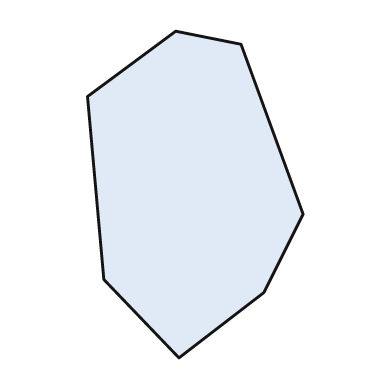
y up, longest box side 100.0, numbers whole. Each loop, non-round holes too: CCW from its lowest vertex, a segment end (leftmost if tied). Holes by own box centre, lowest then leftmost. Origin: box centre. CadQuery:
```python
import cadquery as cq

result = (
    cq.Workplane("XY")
    .moveTo(-5.0, -50.0)
    .lineTo(21.0, -30.0)
    .lineTo(33.0, -6.0)
    .lineTo(14.0, 46.0)
    .lineTo(-6.0, 50.0)
    .lineTo(-33.0, 30.0)
    .lineTo(-28.0, -26.0)
    .close()
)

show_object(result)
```